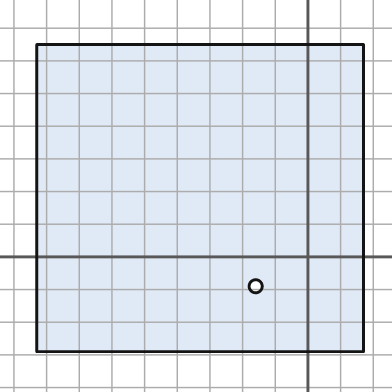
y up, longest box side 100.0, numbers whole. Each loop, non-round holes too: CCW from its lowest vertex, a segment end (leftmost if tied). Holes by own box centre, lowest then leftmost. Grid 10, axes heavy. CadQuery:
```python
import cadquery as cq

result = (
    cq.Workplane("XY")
    .moveTo(-83.0, -29.0)
    .lineTo(17.0, -29.0)
    .lineTo(17.0, 65.0)
    .lineTo(-83.0, 65.0)
    .close()
    .moveTo(-16.0, -9.0)
    .circle(2.0)
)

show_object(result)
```